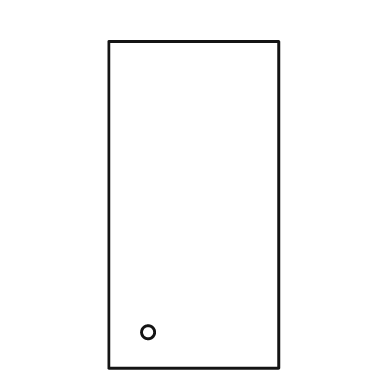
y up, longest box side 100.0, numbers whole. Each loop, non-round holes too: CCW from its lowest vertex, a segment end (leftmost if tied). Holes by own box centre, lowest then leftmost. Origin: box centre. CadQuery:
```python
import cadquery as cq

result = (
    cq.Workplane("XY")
    .moveTo(-26.0, -50.0)
    .lineTo(26.0, -50.0)
    .lineTo(26.0, 50.0)
    .lineTo(-26.0, 50.0)
    .close()
    .moveTo(-14.0, -39.0)
    .circle(2.0)
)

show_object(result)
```